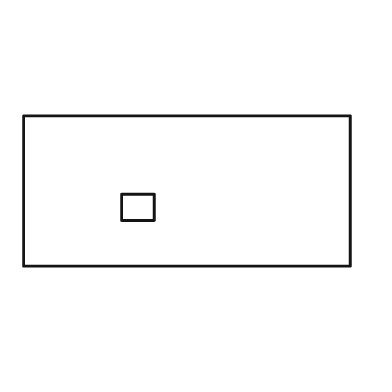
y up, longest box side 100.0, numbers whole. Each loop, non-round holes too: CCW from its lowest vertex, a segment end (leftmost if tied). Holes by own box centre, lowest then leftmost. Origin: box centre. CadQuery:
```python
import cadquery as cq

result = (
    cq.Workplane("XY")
    .moveTo(-50.0, -23.0)
    .lineTo(50.0, -23.0)
    .lineTo(50.0, 23.0)
    .lineTo(-50.0, 23.0)
    .close()
    .moveTo(-20.0, -9.0)
    .lineTo(-10.0, -9.0)
    .lineTo(-10.0, -1.0)
    .lineTo(-20.0, -1.0)
    .close()
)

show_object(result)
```